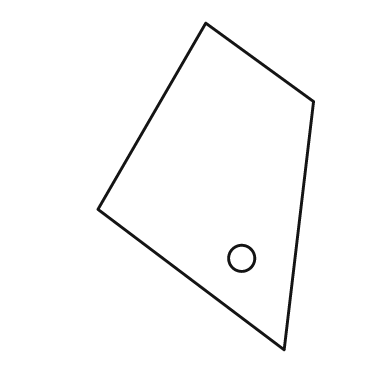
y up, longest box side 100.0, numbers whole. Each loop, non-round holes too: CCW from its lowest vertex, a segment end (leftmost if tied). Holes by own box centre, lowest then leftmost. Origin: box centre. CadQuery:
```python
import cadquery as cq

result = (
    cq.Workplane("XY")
    .moveTo(24.0, -50.0)
    .lineTo(33.0, 26.0)
    .lineTo(0.0, 50.0)
    .lineTo(-33.0, -7.0)
    .close()
    .moveTo(11.0, -22.0)
    .circle(4.0)
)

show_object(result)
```